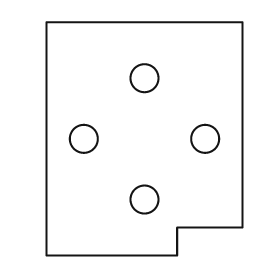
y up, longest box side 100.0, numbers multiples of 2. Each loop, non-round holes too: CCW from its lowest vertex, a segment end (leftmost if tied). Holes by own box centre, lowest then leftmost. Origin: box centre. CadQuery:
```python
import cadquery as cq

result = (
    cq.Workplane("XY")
    .moveTo(-42.0, -50.0)
    .lineTo(14.0, -50.0)
    .lineTo(14.0, -38.0)
    .lineTo(42.0, -38.0)
    .lineTo(42.0, 50.0)
    .lineTo(-42.0, 50.0)
    .close()
    .moveTo(0.0, -26.0)
    .circle(6.0)
    .moveTo(-26.0, 0.0)
    .circle(6.0)
    .moveTo(26.0, 0.0)
    .circle(6.0)
    .moveTo(0.0, 26.0)
    .circle(6.0)
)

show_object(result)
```